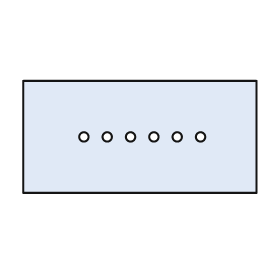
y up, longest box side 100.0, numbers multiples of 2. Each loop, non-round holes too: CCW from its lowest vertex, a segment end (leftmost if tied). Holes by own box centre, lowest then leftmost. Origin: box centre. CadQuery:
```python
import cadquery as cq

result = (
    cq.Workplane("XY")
    .moveTo(-50.0, -24.0)
    .lineTo(50.0, -24.0)
    .lineTo(50.0, 24.0)
    .lineTo(-50.0, 24.0)
    .close()
    .moveTo(-24.0, 0.0)
    .circle(2.0)
    .moveTo(-14.0, 0.0)
    .circle(2.0)
    .moveTo(-4.0, 0.0)
    .circle(2.0)
    .moveTo(6.0, 0.0)
    .circle(2.0)
    .moveTo(16.0, 0.0)
    .circle(2.0)
    .moveTo(26.0, 0.0)
    .circle(2.0)
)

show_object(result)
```